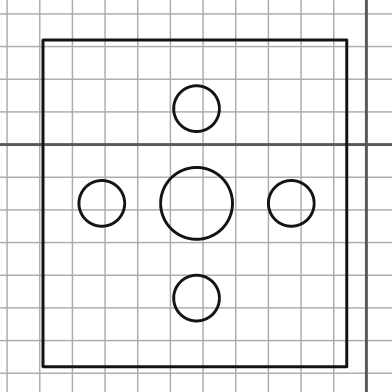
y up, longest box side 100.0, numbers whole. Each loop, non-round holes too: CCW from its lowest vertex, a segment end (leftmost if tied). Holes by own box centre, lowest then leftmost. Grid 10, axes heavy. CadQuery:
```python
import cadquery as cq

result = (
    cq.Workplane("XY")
    .moveTo(-99.0, -68.0)
    .lineTo(-6.0, -68.0)
    .lineTo(-6.0, 32.0)
    .lineTo(-99.0, 32.0)
    .close()
    .moveTo(-52.0, -47.0)
    .circle(7.0)
    .moveTo(-81.0, -18.0)
    .circle(7.0)
    .moveTo(-52.0, -18.0)
    .circle(11.0)
    .moveTo(-23.0, -18.0)
    .circle(7.0)
    .moveTo(-52.0, 11.0)
    .circle(7.0)
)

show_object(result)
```